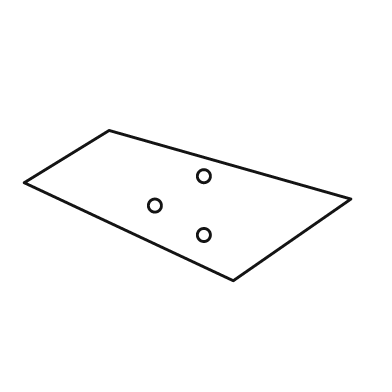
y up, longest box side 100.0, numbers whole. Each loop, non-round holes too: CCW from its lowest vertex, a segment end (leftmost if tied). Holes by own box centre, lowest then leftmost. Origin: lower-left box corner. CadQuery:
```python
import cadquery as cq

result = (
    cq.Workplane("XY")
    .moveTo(64.0, 0.0)
    .lineTo(100.0, 25.0)
    .lineTo(26.0, 46.0)
    .lineTo(0.0, 30.0)
    .close()
    .moveTo(55.0, 14.0)
    .circle(2.0)
    .moveTo(40.0, 23.0)
    .circle(2.0)
    .moveTo(55.0, 32.0)
    .circle(2.0)
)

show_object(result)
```